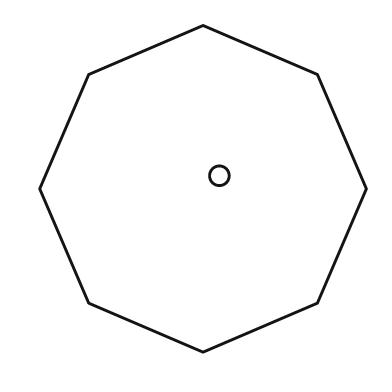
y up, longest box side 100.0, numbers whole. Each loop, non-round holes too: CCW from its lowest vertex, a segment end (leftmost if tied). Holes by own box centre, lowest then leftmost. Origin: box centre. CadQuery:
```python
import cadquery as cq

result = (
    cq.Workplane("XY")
    .moveTo(0.0, -50.0)
    .lineTo(35.0, -35.0)
    .lineTo(50.0, 0.0)
    .lineTo(35.0, 35.0)
    .lineTo(0.0, 50.0)
    .lineTo(-35.0, 35.0)
    .lineTo(-50.0, 0.0)
    .lineTo(-35.0, -35.0)
    .close()
    .moveTo(5.0, 4.0)
    .circle(3.0)
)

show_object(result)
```